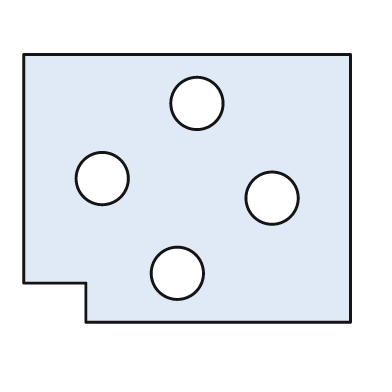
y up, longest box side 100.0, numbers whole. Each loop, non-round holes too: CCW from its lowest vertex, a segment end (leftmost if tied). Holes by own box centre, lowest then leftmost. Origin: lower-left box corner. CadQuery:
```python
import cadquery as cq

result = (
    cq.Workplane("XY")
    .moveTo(19.0, 0.0)
    .lineTo(100.0, 0.0)
    .lineTo(100.0, 82.0)
    .lineTo(0.0, 82.0)
    .lineTo(0.0, 12.0)
    .lineTo(19.0, 12.0)
    .close()
    .moveTo(47.0, 15.0)
    .circle(8.0)
    .moveTo(76.0, 38.0)
    .circle(8.0)
    .moveTo(24.0, 44.0)
    .circle(8.0)
    .moveTo(53.0, 67.0)
    .circle(8.0)
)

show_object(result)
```